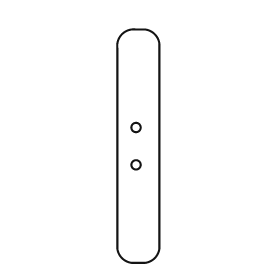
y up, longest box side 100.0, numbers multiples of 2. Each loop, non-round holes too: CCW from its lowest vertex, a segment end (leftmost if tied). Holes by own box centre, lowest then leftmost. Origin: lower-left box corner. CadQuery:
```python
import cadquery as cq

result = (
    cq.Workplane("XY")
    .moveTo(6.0, 0.0)
    .lineTo(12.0, 0.0)
    .threePointArc((16.0, 2.0), (18.0, 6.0))
    .lineTo(18.0, 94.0)
    .threePointArc((16.0, 98.0), (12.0, 100.0))
    .lineTo(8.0, 100.0)
    .threePointArc((2.0, 98.0), (0.0, 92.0))
    .lineTo(0.0, 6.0)
    .threePointArc((2.0, 2.0), (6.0, 0.0))
    .close()
    .moveTo(8.0, 42.0)
    .circle(2.0)
    .moveTo(8.0, 58.0)
    .circle(2.0)
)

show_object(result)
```